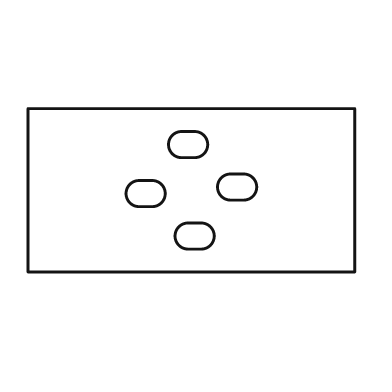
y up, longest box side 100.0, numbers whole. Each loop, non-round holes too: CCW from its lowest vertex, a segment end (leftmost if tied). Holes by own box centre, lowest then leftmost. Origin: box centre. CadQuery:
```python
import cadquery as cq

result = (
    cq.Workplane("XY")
    .moveTo(-50.0, -25.0)
    .lineTo(50.0, -25.0)
    .lineTo(50.0, 25.0)
    .lineTo(-50.0, 25.0)
    .close()
    .moveTo(-1.0, -18.0)
    .lineTo(3.0, -18.0)
    .threePointArc((7.0, -14.0), (3.0, -10.0))
    .lineTo(-1.0, -10.0)
    .threePointArc((-5.0, -14.0), (-1.0, -18.0))
    .close()
    .moveTo(-16.0, -5.0)
    .lineTo(-12.0, -5.0)
    .threePointArc((-8.0, -1.0), (-12.0, 3.0))
    .lineTo(-16.0, 3.0)
    .threePointArc((-20.0, -1.0), (-16.0, -5.0))
    .close()
    .moveTo(12.0, -3.0)
    .lineTo(16.0, -3.0)
    .threePointArc((20.0, 1.0), (16.0, 5.0))
    .lineTo(12.0, 5.0)
    .threePointArc((8.0, 1.0), (12.0, -3.0))
    .close()
    .moveTo(-3.0, 10.0)
    .lineTo(1.0, 10.0)
    .threePointArc((5.0, 14.0), (1.0, 18.0))
    .lineTo(-3.0, 18.0)
    .threePointArc((-7.0, 14.0), (-3.0, 10.0))
    .close()
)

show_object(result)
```